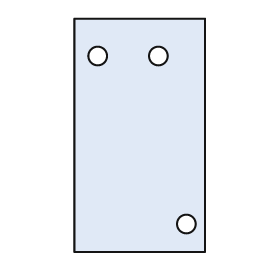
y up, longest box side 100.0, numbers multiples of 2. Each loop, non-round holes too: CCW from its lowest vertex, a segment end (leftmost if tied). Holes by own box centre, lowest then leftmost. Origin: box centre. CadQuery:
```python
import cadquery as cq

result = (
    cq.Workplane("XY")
    .moveTo(-28.0, -50.0)
    .lineTo(28.0, -50.0)
    .lineTo(28.0, 50.0)
    .lineTo(-28.0, 50.0)
    .close()
    .moveTo(20.0, -38.0)
    .circle(4.0)
    .moveTo(-18.0, 34.0)
    .circle(4.0)
    .moveTo(8.0, 34.0)
    .circle(4.0)
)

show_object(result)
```